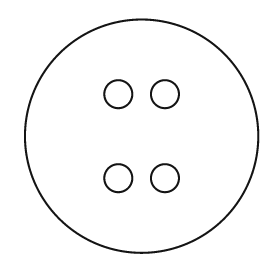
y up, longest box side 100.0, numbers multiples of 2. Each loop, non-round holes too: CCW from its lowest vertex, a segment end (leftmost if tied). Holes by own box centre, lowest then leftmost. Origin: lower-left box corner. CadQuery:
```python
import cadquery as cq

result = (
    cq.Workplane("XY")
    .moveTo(50.0, 50.0)
    .circle(50.0)
    .moveTo(40.0, 32.0)
    .circle(6.0)
    .moveTo(60.0, 32.0)
    .circle(6.0)
    .moveTo(40.0, 68.0)
    .circle(6.0)
    .moveTo(60.0, 68.0)
    .circle(6.0)
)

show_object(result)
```